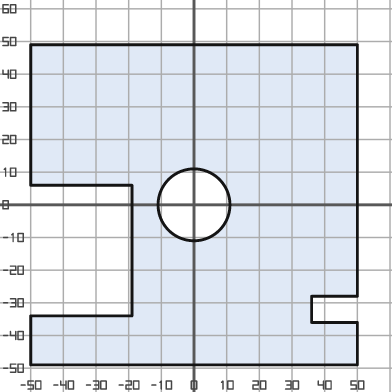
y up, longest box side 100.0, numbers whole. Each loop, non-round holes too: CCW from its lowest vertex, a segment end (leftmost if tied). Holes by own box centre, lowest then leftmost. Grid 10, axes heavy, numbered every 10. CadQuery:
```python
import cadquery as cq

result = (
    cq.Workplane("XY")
    .moveTo(-50.0, -49.0)
    .lineTo(50.0, -49.0)
    .lineTo(50.0, -36.0)
    .lineTo(36.0, -36.0)
    .lineTo(36.0, -28.0)
    .lineTo(50.0, -28.0)
    .lineTo(50.0, 49.0)
    .lineTo(-50.0, 49.0)
    .lineTo(-50.0, 6.0)
    .lineTo(-19.0, 6.0)
    .lineTo(-19.0, -34.0)
    .lineTo(-50.0, -34.0)
    .close()
    .moveTo(0.0, 0.0)
    .circle(11.0)
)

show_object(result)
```